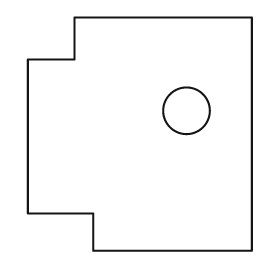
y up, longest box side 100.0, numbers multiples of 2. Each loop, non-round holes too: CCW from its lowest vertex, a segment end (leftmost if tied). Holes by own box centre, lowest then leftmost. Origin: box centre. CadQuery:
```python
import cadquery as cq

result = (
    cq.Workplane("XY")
    .moveTo(-20.0, -50.0)
    .lineTo(48.0, -50.0)
    .lineTo(48.0, 50.0)
    .lineTo(-28.0, 50.0)
    .lineTo(-28.0, 32.0)
    .lineTo(-48.0, 32.0)
    .lineTo(-48.0, -34.0)
    .lineTo(-20.0, -34.0)
    .close()
    .moveTo(20.0, 10.0)
    .circle(10.0)
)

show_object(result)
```